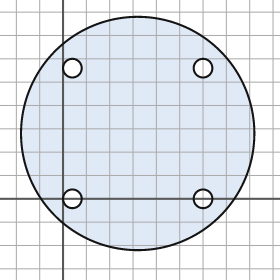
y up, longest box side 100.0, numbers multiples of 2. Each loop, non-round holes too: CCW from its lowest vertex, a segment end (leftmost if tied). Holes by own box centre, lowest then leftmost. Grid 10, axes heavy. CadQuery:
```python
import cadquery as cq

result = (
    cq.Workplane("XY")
    .moveTo(32.0, 28.0)
    .circle(50.0)
    .moveTo(4.0, 0.0)
    .circle(4.0)
    .moveTo(60.0, 0.0)
    .circle(4.0)
    .moveTo(4.0, 56.0)
    .circle(4.0)
    .moveTo(60.0, 56.0)
    .circle(4.0)
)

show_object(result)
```